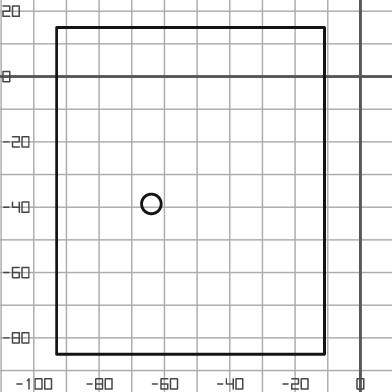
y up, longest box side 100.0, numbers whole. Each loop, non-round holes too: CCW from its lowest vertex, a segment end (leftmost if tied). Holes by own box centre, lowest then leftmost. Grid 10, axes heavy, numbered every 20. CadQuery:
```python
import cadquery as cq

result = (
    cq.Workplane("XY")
    .moveTo(-93.0, -85.0)
    .lineTo(-11.0, -85.0)
    .lineTo(-11.0, 15.0)
    .lineTo(-93.0, 15.0)
    .close()
    .moveTo(-64.0, -39.0)
    .circle(3.0)
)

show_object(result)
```